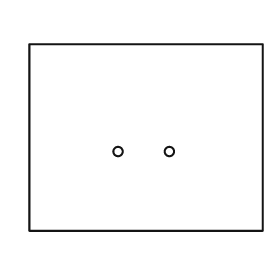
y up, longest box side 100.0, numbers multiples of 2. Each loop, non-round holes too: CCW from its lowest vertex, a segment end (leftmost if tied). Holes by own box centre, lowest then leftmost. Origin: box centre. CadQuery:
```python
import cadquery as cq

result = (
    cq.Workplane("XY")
    .moveTo(-50.0, -40.0)
    .lineTo(50.0, -40.0)
    .lineTo(50.0, 40.0)
    .lineTo(-50.0, 40.0)
    .close()
    .moveTo(-12.0, -6.0)
    .circle(2.0)
    .moveTo(10.0, -6.0)
    .circle(2.0)
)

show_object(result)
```